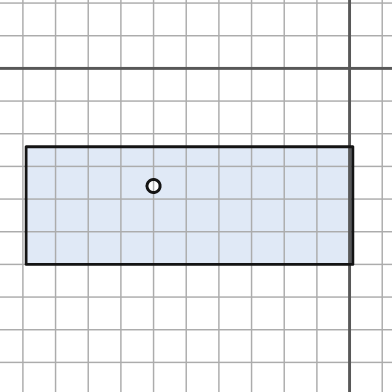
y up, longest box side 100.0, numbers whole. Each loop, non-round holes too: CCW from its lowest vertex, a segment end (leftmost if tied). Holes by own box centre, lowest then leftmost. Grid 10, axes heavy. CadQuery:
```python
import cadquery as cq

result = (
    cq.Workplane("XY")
    .moveTo(-99.0, -60.0)
    .lineTo(1.0, -60.0)
    .lineTo(1.0, -24.0)
    .lineTo(-99.0, -24.0)
    .close()
    .moveTo(-60.0, -36.0)
    .circle(2.0)
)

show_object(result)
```